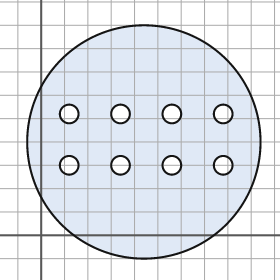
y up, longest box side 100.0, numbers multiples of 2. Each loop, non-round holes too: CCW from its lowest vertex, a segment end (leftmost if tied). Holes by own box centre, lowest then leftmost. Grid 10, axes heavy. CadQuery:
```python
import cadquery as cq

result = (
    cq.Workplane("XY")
    .moveTo(44.0, 40.0)
    .circle(50.0)
    .moveTo(12.0, 30.0)
    .circle(4.0)
    .moveTo(34.0, 30.0)
    .circle(4.0)
    .moveTo(56.0, 30.0)
    .circle(4.0)
    .moveTo(78.0, 30.0)
    .circle(4.0)
    .moveTo(12.0, 52.0)
    .circle(4.0)
    .moveTo(34.0, 52.0)
    .circle(4.0)
    .moveTo(56.0, 52.0)
    .circle(4.0)
    .moveTo(78.0, 52.0)
    .circle(4.0)
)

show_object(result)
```